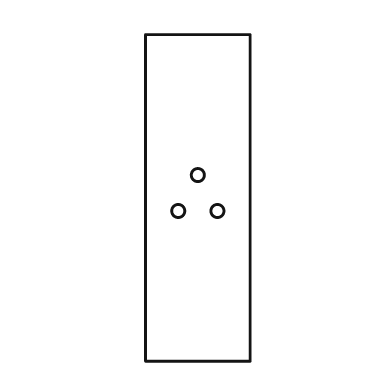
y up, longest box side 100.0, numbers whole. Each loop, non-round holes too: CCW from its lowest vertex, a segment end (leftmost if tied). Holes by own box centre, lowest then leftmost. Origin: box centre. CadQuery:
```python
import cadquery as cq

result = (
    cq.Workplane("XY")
    .moveTo(-16.0, -50.0)
    .lineTo(16.0, -50.0)
    .lineTo(16.0, 50.0)
    .lineTo(-16.0, 50.0)
    .close()
    .moveTo(-6.0, -4.0)
    .circle(2.0)
    .moveTo(6.0, -4.0)
    .circle(2.0)
    .moveTo(0.0, 7.0)
    .circle(2.0)
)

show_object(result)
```